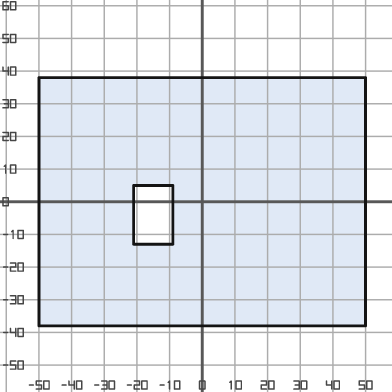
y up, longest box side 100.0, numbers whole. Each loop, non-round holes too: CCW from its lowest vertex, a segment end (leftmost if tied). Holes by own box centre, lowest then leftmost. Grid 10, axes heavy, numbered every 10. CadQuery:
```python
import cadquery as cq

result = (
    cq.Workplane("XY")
    .moveTo(-50.0, -38.0)
    .lineTo(50.0, -38.0)
    .lineTo(50.0, 38.0)
    .lineTo(-50.0, 38.0)
    .close()
    .moveTo(-21.0, -13.0)
    .lineTo(-9.0, -13.0)
    .lineTo(-9.0, 5.0)
    .lineTo(-21.0, 5.0)
    .close()
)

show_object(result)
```